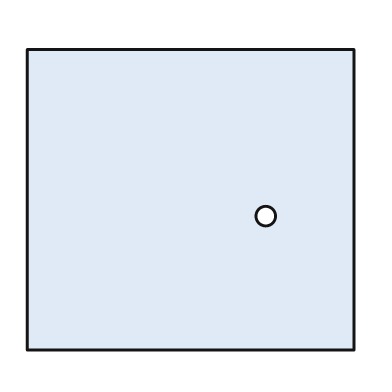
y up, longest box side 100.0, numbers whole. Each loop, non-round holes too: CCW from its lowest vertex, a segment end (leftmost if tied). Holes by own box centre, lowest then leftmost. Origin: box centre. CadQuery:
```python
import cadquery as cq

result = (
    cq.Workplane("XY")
    .moveTo(-50.0, -46.0)
    .lineTo(50.0, -46.0)
    .lineTo(50.0, 46.0)
    .lineTo(-50.0, 46.0)
    .close()
    .moveTo(23.0, -5.0)
    .circle(3.0)
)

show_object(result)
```